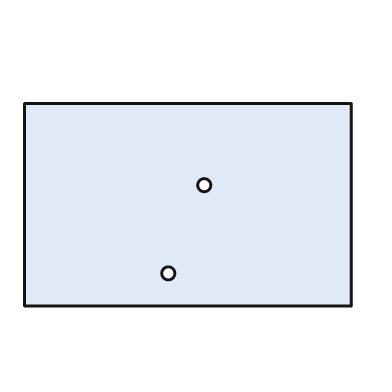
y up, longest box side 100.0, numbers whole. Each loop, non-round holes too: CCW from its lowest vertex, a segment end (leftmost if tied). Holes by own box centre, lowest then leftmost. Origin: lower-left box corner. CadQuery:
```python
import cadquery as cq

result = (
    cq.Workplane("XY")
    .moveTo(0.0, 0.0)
    .lineTo(100.0, 0.0)
    .lineTo(100.0, 62.0)
    .lineTo(0.0, 62.0)
    .close()
    .moveTo(44.0, 10.0)
    .circle(2.0)
    .moveTo(55.0, 37.0)
    .circle(2.0)
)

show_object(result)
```